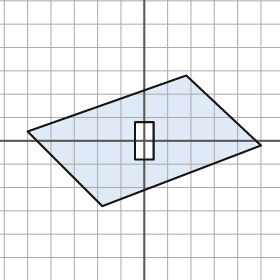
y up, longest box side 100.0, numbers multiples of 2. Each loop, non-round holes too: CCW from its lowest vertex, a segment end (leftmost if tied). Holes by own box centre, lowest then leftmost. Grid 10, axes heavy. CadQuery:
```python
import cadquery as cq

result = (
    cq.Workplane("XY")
    .moveTo(-18.0, -28.0)
    .lineTo(50.0, -2.0)
    .lineTo(18.0, 28.0)
    .lineTo(-50.0, 4.0)
    .close()
    .moveTo(-4.0, -8.0)
    .lineTo(4.0, -8.0)
    .lineTo(4.0, 8.0)
    .lineTo(-4.0, 8.0)
    .close()
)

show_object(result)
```